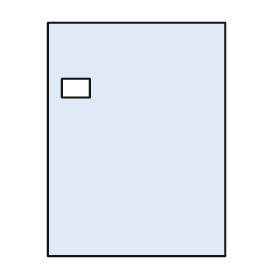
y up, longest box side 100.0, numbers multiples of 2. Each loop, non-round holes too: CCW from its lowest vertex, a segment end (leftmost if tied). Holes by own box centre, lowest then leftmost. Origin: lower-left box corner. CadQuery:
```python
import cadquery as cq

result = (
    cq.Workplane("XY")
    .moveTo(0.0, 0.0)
    .lineTo(76.0, 0.0)
    .lineTo(76.0, 100.0)
    .lineTo(0.0, 100.0)
    .close()
    .moveTo(6.0, 68.0)
    .lineTo(18.0, 68.0)
    .lineTo(18.0, 76.0)
    .lineTo(6.0, 76.0)
    .close()
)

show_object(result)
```